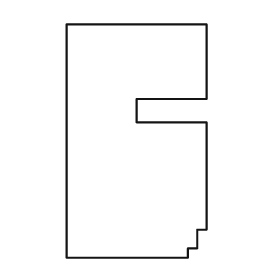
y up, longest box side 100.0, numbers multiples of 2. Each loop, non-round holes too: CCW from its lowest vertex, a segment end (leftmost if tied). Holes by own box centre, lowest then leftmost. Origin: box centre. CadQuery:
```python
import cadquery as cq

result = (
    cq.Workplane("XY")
    .moveTo(-30.0, -50.0)
    .lineTo(22.0, -50.0)
    .lineTo(22.0, -46.0)
    .lineTo(26.0, -46.0)
    .lineTo(26.0, -38.0)
    .lineTo(30.0, -38.0)
    .lineTo(30.0, 8.0)
    .lineTo(0.0, 8.0)
    .lineTo(0.0, 18.0)
    .lineTo(30.0, 18.0)
    .lineTo(30.0, 50.0)
    .lineTo(-30.0, 50.0)
    .close()
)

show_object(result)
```